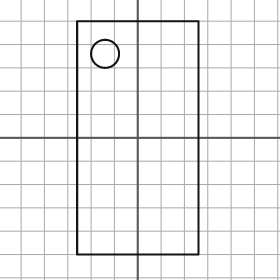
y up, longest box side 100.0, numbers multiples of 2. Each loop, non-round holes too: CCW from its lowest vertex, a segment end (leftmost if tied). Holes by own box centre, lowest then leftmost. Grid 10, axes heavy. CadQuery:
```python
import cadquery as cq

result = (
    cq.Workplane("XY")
    .moveTo(-26.0, -50.0)
    .lineTo(26.0, -50.0)
    .lineTo(26.0, 50.0)
    .lineTo(-26.0, 50.0)
    .close()
    .moveTo(-14.0, 36.0)
    .circle(6.0)
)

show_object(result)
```